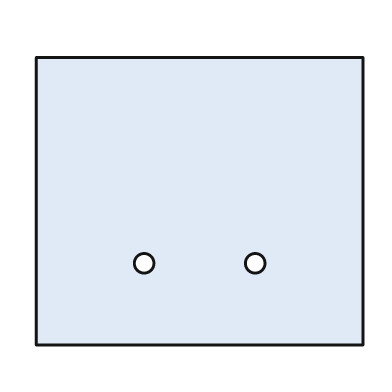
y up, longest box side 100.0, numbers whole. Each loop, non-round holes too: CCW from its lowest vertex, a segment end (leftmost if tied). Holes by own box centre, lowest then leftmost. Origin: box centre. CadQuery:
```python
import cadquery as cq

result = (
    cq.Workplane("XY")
    .moveTo(-50.0, -44.0)
    .lineTo(50.0, -44.0)
    .lineTo(50.0, 44.0)
    .lineTo(-50.0, 44.0)
    .close()
    .moveTo(-17.0, -19.0)
    .circle(3.0)
    .moveTo(17.0, -19.0)
    .circle(3.0)
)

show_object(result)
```